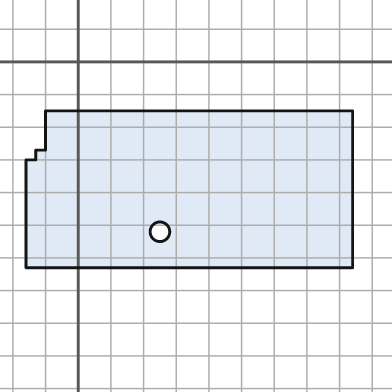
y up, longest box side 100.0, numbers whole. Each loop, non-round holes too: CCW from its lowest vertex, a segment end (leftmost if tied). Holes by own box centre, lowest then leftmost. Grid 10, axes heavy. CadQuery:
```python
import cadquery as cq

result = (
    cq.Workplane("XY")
    .moveTo(-16.0, -63.0)
    .lineTo(84.0, -63.0)
    .lineTo(84.0, -15.0)
    .lineTo(-10.0, -15.0)
    .lineTo(-10.0, -27.0)
    .lineTo(-13.0, -27.0)
    .lineTo(-13.0, -30.0)
    .lineTo(-16.0, -30.0)
    .close()
    .moveTo(25.0, -52.0)
    .circle(3.0)
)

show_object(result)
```